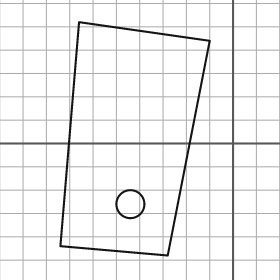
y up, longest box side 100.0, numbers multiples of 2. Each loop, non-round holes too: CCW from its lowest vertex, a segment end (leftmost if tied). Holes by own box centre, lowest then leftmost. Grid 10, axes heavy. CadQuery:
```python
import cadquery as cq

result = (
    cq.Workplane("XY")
    .moveTo(-28.0, -48.0)
    .lineTo(-10.0, 44.0)
    .lineTo(-66.0, 52.0)
    .lineTo(-74.0, -44.0)
    .close()
    .moveTo(-44.0, -26.0)
    .circle(6.0)
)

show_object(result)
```